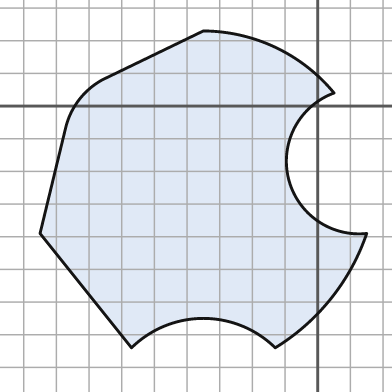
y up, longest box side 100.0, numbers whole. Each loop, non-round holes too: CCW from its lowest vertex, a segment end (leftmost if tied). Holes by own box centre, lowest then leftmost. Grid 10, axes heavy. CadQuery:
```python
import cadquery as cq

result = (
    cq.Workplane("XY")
    .moveTo(-57.0, -74.0)
    .threePointArc((-35.0, -65.0), (-13.0, -74.0))
    .threePointArc((4.0, -59.0), (15.0, -39.0))
    .threePointArc((-9.0, -22.0), (5.0, 4.0))
    .threePointArc((-13.0, 18.0), (-35.0, 23.0))
    .lineTo(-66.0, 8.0)
    .threePointArc((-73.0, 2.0), (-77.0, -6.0))
    .lineTo(-85.0, -39.0)
    .close()
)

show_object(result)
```